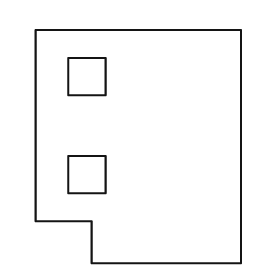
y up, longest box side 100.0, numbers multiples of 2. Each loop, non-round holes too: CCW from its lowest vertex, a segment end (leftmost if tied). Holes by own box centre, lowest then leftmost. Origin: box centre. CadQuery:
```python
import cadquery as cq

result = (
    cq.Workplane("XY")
    .moveTo(-20.0, -50.0)
    .lineTo(44.0, -50.0)
    .lineTo(44.0, 50.0)
    .lineTo(-44.0, 50.0)
    .lineTo(-44.0, -32.0)
    .lineTo(-20.0, -32.0)
    .close()
    .moveTo(-30.0, -20.0)
    .lineTo(-14.0, -20.0)
    .lineTo(-14.0, -4.0)
    .lineTo(-30.0, -4.0)
    .close()
    .moveTo(-30.0, 22.0)
    .lineTo(-14.0, 22.0)
    .lineTo(-14.0, 38.0)
    .lineTo(-30.0, 38.0)
    .close()
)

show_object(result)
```